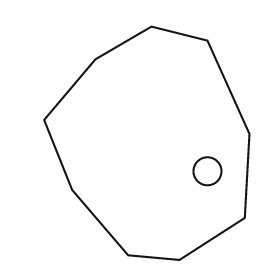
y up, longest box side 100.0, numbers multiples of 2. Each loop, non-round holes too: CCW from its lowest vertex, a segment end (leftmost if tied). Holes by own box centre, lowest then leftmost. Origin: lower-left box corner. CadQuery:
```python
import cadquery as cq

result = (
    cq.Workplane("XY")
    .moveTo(58.0, 0.0)
    .lineTo(86.0, 18.0)
    .lineTo(88.0, 54.0)
    .lineTo(70.0, 94.0)
    .lineTo(46.0, 100.0)
    .lineTo(22.0, 86.0)
    .lineTo(0.0, 60.0)
    .lineTo(12.0, 30.0)
    .lineTo(36.0, 2.0)
    .close()
    .moveTo(70.0, 38.0)
    .circle(6.0)
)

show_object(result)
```